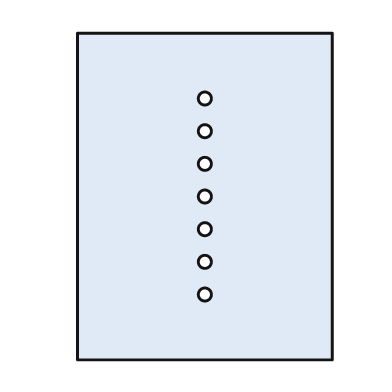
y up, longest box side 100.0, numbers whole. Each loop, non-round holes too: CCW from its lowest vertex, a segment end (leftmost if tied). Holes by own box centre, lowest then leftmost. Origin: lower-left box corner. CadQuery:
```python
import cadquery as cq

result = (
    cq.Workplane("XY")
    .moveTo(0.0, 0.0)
    .lineTo(78.0, 0.0)
    .lineTo(78.0, 100.0)
    .lineTo(0.0, 100.0)
    .close()
    .moveTo(39.0, 20.0)
    .circle(2.0)
    .moveTo(39.0, 30.0)
    .circle(2.0)
    .moveTo(39.0, 40.0)
    .circle(2.0)
    .moveTo(39.0, 50.0)
    .circle(2.0)
    .moveTo(39.0, 60.0)
    .circle(2.0)
    .moveTo(39.0, 70.0)
    .circle(2.0)
    .moveTo(39.0, 80.0)
    .circle(2.0)
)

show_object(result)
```